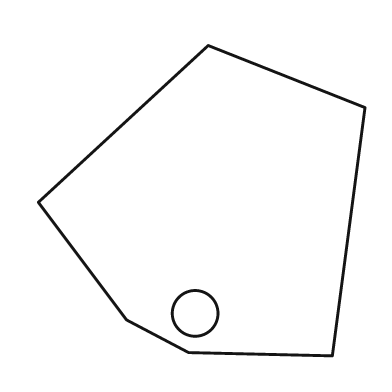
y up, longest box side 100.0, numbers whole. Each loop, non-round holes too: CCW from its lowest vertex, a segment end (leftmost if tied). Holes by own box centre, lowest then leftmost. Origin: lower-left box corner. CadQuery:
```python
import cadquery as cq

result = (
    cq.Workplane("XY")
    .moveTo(90.0, 0.0)
    .lineTo(100.0, 76.0)
    .lineTo(52.0, 95.0)
    .lineTo(0.0, 47.0)
    .lineTo(27.0, 11.0)
    .lineTo(46.0, 1.0)
    .close()
    .moveTo(48.0, 13.0)
    .circle(7.0)
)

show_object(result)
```